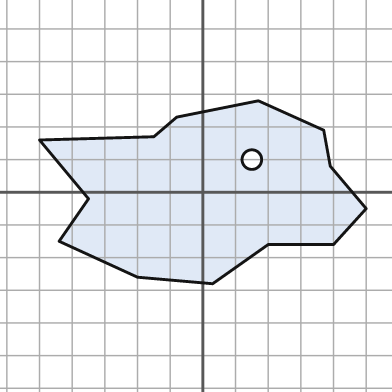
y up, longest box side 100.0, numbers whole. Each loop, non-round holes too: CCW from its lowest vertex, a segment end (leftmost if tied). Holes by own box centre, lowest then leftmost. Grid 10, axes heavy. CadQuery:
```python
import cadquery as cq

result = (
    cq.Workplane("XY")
    .moveTo(3.0, -28.0)
    .lineTo(20.0, -16.0)
    .lineTo(40.0, -16.0)
    .lineTo(50.0, -5.0)
    .lineTo(39.0, 8.0)
    .lineTo(37.0, 19.0)
    .lineTo(17.0, 28.0)
    .lineTo(-8.0, 23.0)
    .lineTo(-15.0, 17.0)
    .lineTo(-50.0, 16.0)
    .lineTo(-35.0, -2.0)
    .lineTo(-44.0, -15.0)
    .lineTo(-20.0, -26.0)
    .close()
    .moveTo(15.0, 10.0)
    .circle(3.0)
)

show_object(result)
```